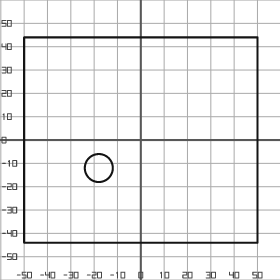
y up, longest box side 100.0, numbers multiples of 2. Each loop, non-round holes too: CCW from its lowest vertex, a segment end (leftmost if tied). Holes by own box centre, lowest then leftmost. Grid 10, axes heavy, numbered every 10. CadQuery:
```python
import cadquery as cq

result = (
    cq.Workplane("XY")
    .moveTo(-50.0, -44.0)
    .lineTo(50.0, -44.0)
    .lineTo(50.0, 44.0)
    .lineTo(-50.0, 44.0)
    .close()
    .moveTo(-18.0, -12.0)
    .circle(6.0)
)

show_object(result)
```